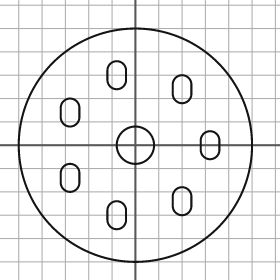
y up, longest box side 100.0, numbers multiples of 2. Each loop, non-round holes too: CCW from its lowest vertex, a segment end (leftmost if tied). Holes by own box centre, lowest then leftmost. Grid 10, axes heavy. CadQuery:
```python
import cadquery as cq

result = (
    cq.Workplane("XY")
    .moveTo(0.0, 0.0)
    .circle(50.0)
    .moveTo(-12.0, -32.0)
    .threePointArc((-8.0, -36.0), (-4.0, -32.0))
    .lineTo(-4.0, -28.0)
    .threePointArc((-8.0, -24.0), (-12.0, -28.0))
    .close()
    .moveTo(16.0, -26.0)
    .threePointArc((20.0, -30.0), (24.0, -26.0))
    .lineTo(24.0, -22.0)
    .threePointArc((20.0, -18.0), (16.0, -22.0))
    .close()
    .moveTo(-32.0, -16.0)
    .threePointArc((-28.0, -20.0), (-24.0, -16.0))
    .lineTo(-24.0, -12.0)
    .threePointArc((-28.0, -8.0), (-32.0, -12.0))
    .close()
    .moveTo(0.0, 0.0)
    .circle(8.0)
    .moveTo(28.0, -2.0)
    .threePointArc((32.0, -6.0), (36.0, -2.0))
    .lineTo(36.0, 2.0)
    .threePointArc((32.0, 6.0), (28.0, 2.0))
    .close()
    .moveTo(-32.0, 12.0)
    .threePointArc((-28.0, 8.0), (-24.0, 12.0))
    .lineTo(-24.0, 16.0)
    .threePointArc((-28.0, 20.0), (-32.0, 16.0))
    .close()
    .moveTo(16.0, 22.0)
    .threePointArc((20.0, 18.0), (24.0, 22.0))
    .lineTo(24.0, 26.0)
    .threePointArc((20.0, 30.0), (16.0, 26.0))
    .close()
    .moveTo(-12.0, 28.0)
    .threePointArc((-8.0, 24.0), (-4.0, 28.0))
    .lineTo(-4.0, 32.0)
    .threePointArc((-8.0, 36.0), (-12.0, 32.0))
    .close()
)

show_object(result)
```